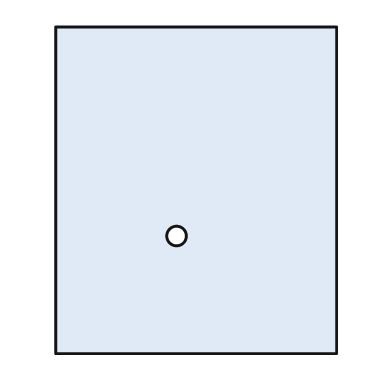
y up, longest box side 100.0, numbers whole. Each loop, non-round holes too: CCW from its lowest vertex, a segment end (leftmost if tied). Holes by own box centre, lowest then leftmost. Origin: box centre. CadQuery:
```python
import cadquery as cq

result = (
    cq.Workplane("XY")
    .moveTo(-43.0, -50.0)
    .lineTo(43.0, -50.0)
    .lineTo(43.0, 50.0)
    .lineTo(-43.0, 50.0)
    .close()
    .moveTo(-6.0, -14.0)
    .circle(3.0)
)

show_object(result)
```